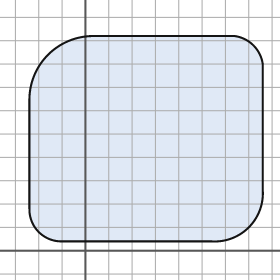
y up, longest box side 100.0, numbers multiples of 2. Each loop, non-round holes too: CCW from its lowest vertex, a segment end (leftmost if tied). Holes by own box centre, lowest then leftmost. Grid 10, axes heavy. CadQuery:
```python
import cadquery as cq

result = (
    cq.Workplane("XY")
    .moveTo(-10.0, 4.0)
    .lineTo(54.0, 4.0)
    .threePointArc((70.0, 10.0), (76.0, 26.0))
    .lineTo(76.0, 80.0)
    .threePointArc((72.0, 88.0), (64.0, 92.0))
    .lineTo(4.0, 92.0)
    .threePointArc((-16.0, 84.0), (-24.0, 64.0))
    .lineTo(-24.0, 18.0)
    .threePointArc((-20.0, 8.0), (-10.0, 4.0))
    .close()
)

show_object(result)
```